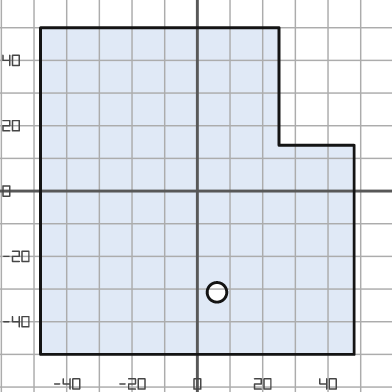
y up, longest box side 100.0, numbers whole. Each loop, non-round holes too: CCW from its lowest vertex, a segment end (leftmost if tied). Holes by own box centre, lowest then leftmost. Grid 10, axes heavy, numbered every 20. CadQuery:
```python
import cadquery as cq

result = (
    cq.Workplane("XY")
    .moveTo(-48.0, -50.0)
    .lineTo(48.0, -50.0)
    .lineTo(48.0, 14.0)
    .lineTo(25.0, 14.0)
    .lineTo(25.0, 50.0)
    .lineTo(-48.0, 50.0)
    .close()
    .moveTo(6.0, -31.0)
    .circle(3.0)
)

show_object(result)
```